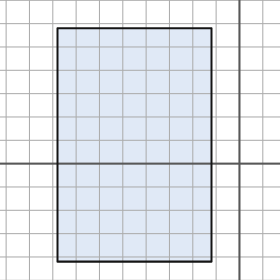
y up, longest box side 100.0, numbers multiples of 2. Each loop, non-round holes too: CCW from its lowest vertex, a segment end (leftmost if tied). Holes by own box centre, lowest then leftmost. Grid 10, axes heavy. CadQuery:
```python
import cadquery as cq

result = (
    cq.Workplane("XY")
    .moveTo(-78.0, -42.0)
    .lineTo(-12.0, -42.0)
    .lineTo(-12.0, 58.0)
    .lineTo(-78.0, 58.0)
    .close()
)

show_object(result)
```